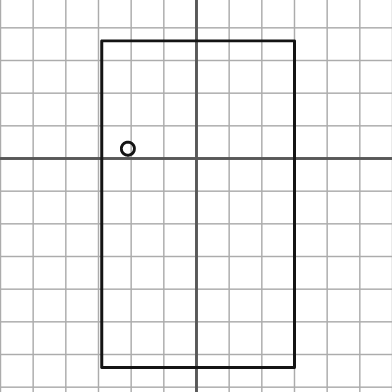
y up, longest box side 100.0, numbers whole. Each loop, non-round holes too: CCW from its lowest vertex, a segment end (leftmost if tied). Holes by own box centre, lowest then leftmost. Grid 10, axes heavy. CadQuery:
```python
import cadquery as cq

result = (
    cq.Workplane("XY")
    .moveTo(-29.0, -64.0)
    .lineTo(30.0, -64.0)
    .lineTo(30.0, 36.0)
    .lineTo(-29.0, 36.0)
    .close()
    .moveTo(-21.0, 3.0)
    .circle(2.0)
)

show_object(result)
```